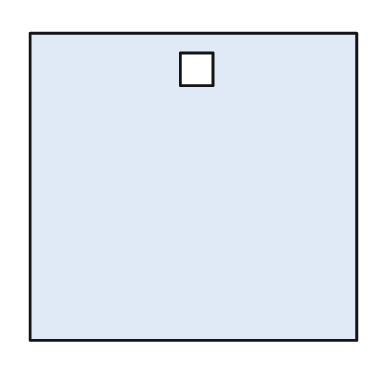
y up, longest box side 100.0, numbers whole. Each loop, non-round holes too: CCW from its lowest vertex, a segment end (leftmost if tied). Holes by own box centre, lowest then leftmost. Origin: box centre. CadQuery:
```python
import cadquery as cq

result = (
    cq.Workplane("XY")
    .moveTo(-50.0, -47.0)
    .lineTo(50.0, -47.0)
    .lineTo(50.0, 47.0)
    .lineTo(-50.0, 47.0)
    .close()
    .moveTo(-4.0, 31.0)
    .lineTo(6.0, 31.0)
    .lineTo(6.0, 41.0)
    .lineTo(-4.0, 41.0)
    .close()
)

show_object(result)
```